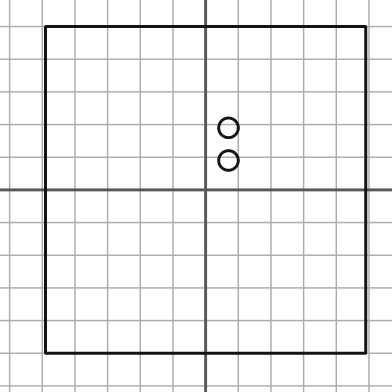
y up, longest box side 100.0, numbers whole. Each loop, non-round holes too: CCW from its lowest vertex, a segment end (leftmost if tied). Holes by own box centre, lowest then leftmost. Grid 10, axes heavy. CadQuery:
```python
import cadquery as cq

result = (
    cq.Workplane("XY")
    .moveTo(-49.0, -50.0)
    .lineTo(49.0, -50.0)
    .lineTo(49.0, 50.0)
    .lineTo(-49.0, 50.0)
    .close()
    .moveTo(7.0, 9.0)
    .circle(3.0)
    .moveTo(7.0, 19.0)
    .circle(3.0)
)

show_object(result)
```